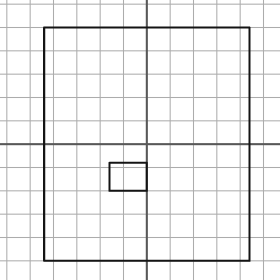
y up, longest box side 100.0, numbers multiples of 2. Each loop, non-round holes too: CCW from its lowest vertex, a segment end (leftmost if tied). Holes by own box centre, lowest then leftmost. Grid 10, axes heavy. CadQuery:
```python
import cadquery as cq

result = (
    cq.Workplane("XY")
    .moveTo(-44.0, -50.0)
    .lineTo(44.0, -50.0)
    .lineTo(44.0, 50.0)
    .lineTo(-44.0, 50.0)
    .close()
    .moveTo(-16.0, -20.0)
    .lineTo(0.0, -20.0)
    .lineTo(0.0, -8.0)
    .lineTo(-16.0, -8.0)
    .close()
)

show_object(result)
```